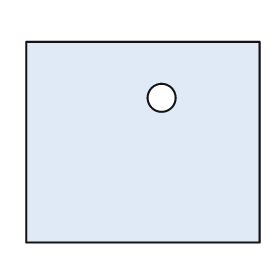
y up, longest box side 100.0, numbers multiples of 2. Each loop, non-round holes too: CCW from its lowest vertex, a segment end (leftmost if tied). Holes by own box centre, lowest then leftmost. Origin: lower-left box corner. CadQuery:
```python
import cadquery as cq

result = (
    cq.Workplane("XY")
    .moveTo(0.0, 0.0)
    .lineTo(100.0, 0.0)
    .lineTo(100.0, 86.0)
    .lineTo(0.0, 86.0)
    .close()
    .moveTo(58.0, 62.0)
    .circle(6.0)
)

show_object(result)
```